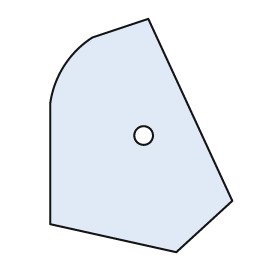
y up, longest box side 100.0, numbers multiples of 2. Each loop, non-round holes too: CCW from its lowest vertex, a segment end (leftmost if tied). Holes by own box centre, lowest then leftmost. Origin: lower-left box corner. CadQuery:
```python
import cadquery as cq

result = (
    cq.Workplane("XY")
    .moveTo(54.0, 0.0)
    .lineTo(78.0, 22.0)
    .lineTo(42.0, 100.0)
    .lineTo(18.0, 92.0)
    .threePointArc((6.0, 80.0), (0.0, 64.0))
    .lineTo(0.0, 12.0)
    .close()
    .moveTo(40.0, 50.0)
    .circle(4.0)
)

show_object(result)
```